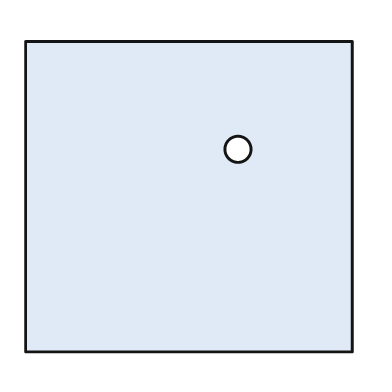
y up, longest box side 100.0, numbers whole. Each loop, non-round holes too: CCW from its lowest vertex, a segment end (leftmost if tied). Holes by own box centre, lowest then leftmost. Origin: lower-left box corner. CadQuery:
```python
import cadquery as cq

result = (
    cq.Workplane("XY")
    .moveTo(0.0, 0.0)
    .lineTo(100.0, 0.0)
    .lineTo(100.0, 95.0)
    .lineTo(0.0, 95.0)
    .close()
    .moveTo(65.0, 62.0)
    .circle(4.0)
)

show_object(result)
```